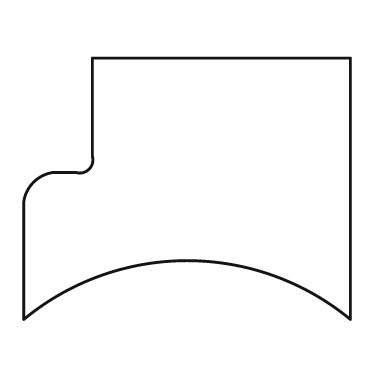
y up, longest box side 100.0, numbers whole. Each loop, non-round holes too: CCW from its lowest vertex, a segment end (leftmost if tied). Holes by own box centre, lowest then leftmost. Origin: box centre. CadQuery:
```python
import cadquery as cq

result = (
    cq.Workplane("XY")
    .moveTo(-50.0, -40.0)
    .threePointArc((0.0, -22.0), (50.0, -40.0))
    .lineTo(50.0, 40.0)
    .lineTo(-29.0, 40.0)
    .lineTo(-29.0, 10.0)
    .threePointArc((-30.0, 6.0), (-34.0, 5.0))
    .lineTo(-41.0, 5.0)
    .threePointArc((-47.0, 2.0), (-50.0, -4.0))
    .close()
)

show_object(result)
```